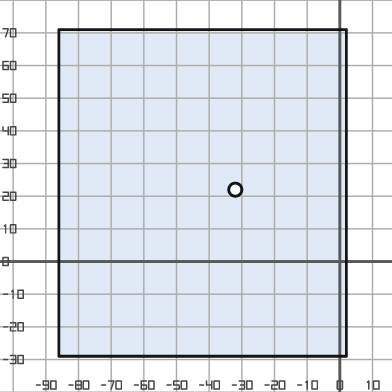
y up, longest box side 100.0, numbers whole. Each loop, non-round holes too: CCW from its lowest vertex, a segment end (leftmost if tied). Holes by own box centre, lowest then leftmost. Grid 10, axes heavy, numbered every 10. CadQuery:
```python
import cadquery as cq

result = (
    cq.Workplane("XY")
    .moveTo(-86.0, -29.0)
    .lineTo(2.0, -29.0)
    .lineTo(2.0, 71.0)
    .lineTo(-86.0, 71.0)
    .close()
    .moveTo(-32.0, 22.0)
    .circle(2.0)
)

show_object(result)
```